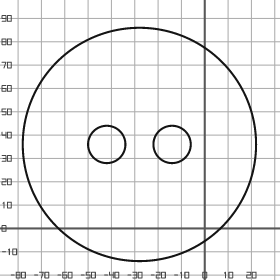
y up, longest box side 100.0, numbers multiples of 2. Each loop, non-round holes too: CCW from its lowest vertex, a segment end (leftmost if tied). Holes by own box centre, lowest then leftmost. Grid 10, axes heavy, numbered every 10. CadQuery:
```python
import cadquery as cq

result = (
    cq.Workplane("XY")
    .moveTo(-28.0, 36.0)
    .circle(50.0)
    .moveTo(-42.0, 36.0)
    .circle(8.0)
    .moveTo(-14.0, 36.0)
    .circle(8.0)
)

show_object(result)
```